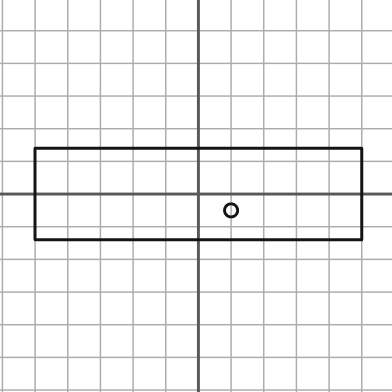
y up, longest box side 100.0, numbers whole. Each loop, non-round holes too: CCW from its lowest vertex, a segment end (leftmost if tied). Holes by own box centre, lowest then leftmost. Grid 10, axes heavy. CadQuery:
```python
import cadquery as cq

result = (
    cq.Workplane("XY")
    .moveTo(-50.0, -14.0)
    .lineTo(50.0, -14.0)
    .lineTo(50.0, 14.0)
    .lineTo(-50.0, 14.0)
    .close()
    .moveTo(10.0, -5.0)
    .circle(2.0)
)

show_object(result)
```